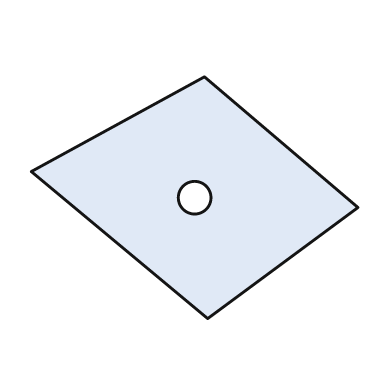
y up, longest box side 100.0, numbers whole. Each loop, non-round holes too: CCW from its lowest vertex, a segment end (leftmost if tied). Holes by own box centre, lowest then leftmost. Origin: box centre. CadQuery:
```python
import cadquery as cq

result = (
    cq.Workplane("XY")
    .moveTo(4.0, -37.0)
    .lineTo(50.0, -3.0)
    .lineTo(3.0, 37.0)
    .lineTo(-50.0, 8.0)
    .close()
    .moveTo(0.0, 0.0)
    .circle(5.0)
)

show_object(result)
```